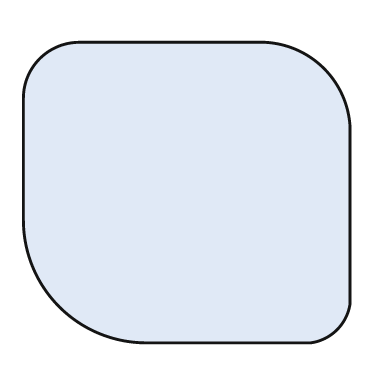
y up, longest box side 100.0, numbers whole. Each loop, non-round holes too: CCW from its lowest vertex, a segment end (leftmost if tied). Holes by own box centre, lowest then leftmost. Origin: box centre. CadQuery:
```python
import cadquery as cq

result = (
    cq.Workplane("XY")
    .moveTo(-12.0, -46.0)
    .lineTo(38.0, -46.0)
    .threePointArc((46.0, -42.0), (50.0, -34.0))
    .lineTo(50.0, 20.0)
    .threePointArc((42.0, 38.0), (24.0, 46.0))
    .lineTo(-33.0, 46.0)
    .threePointArc((-45.0, 41.0), (-50.0, 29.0))
    .lineTo(-50.0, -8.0)
    .threePointArc((-39.0, -35.0), (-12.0, -46.0))
    .close()
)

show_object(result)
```